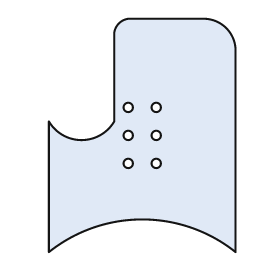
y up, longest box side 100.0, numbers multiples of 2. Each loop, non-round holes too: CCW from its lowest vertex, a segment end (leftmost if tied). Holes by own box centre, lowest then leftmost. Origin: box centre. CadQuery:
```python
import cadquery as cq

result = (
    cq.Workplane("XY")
    .moveTo(-40.0, -50.0)
    .threePointArc((0.0, -36.0), (40.0, -50.0))
    .lineTo(40.0, 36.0)
    .threePointArc((36.0, 46.0), (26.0, 50.0))
    .lineTo(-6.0, 50.0)
    .threePointArc((-10.0, 48.0), (-12.0, 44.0))
    .lineTo(-12.0, 6.0)
    .threePointArc((-26.0, -2.0), (-40.0, 6.0))
    .close()
    .moveTo(-6.0, -12.0)
    .circle(2.0)
    .moveTo(6.0, -12.0)
    .circle(2.0)
    .moveTo(-6.0, 0.0)
    .circle(2.0)
    .moveTo(6.0, 0.0)
    .circle(2.0)
    .moveTo(-6.0, 12.0)
    .circle(2.0)
    .moveTo(6.0, 12.0)
    .circle(2.0)
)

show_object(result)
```